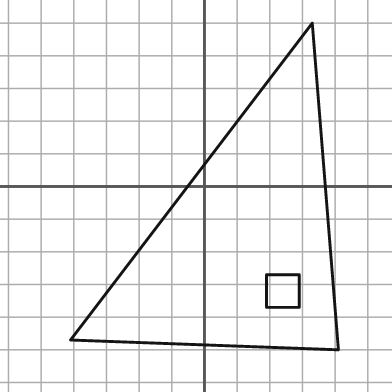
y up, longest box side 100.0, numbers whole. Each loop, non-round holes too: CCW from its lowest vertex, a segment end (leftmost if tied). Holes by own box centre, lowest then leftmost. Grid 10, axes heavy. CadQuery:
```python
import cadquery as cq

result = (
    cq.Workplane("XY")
    .moveTo(41.0, -50.0)
    .lineTo(33.0, 50.0)
    .lineTo(-41.0, -47.0)
    .close()
    .moveTo(19.0, -37.0)
    .lineTo(29.0, -37.0)
    .lineTo(29.0, -27.0)
    .lineTo(19.0, -27.0)
    .close()
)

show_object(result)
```